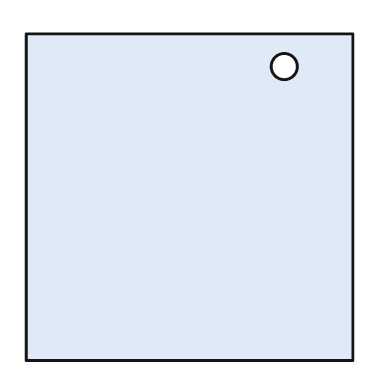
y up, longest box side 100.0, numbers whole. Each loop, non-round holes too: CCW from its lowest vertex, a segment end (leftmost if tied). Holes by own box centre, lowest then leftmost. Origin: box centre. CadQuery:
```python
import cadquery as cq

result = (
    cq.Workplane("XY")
    .moveTo(-50.0, -50.0)
    .lineTo(50.0, -50.0)
    .lineTo(50.0, 50.0)
    .lineTo(-50.0, 50.0)
    .close()
    .moveTo(29.0, 40.0)
    .circle(4.0)
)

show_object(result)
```